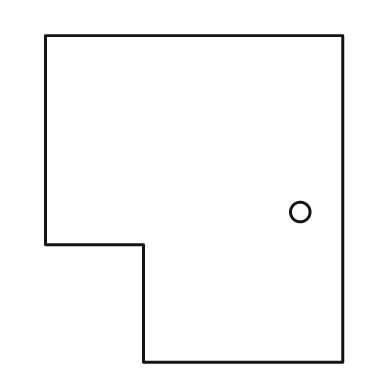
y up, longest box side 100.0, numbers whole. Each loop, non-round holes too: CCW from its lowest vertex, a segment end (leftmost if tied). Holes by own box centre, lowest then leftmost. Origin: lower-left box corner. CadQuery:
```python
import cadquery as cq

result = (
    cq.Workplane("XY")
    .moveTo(30.0, 0.0)
    .lineTo(91.0, 0.0)
    .lineTo(91.0, 100.0)
    .lineTo(0.0, 100.0)
    .lineTo(0.0, 36.0)
    .lineTo(30.0, 36.0)
    .close()
    .moveTo(78.0, 46.0)
    .circle(3.0)
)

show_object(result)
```